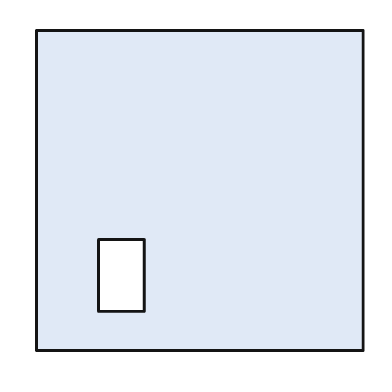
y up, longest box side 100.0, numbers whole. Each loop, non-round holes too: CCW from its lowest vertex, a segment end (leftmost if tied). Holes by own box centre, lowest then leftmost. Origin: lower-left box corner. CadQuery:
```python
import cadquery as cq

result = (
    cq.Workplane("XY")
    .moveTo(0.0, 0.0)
    .lineTo(100.0, 0.0)
    .lineTo(100.0, 98.0)
    .lineTo(0.0, 98.0)
    .close()
    .moveTo(19.0, 12.0)
    .lineTo(33.0, 12.0)
    .lineTo(33.0, 34.0)
    .lineTo(19.0, 34.0)
    .close()
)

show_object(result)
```